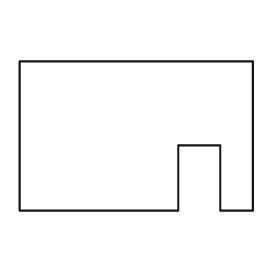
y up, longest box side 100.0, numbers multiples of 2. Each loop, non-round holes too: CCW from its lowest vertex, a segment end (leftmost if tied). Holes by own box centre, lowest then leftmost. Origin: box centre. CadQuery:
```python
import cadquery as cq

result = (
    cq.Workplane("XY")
    .moveTo(-50.0, -32.0)
    .lineTo(18.0, -32.0)
    .lineTo(18.0, -4.0)
    .lineTo(36.0, -4.0)
    .lineTo(36.0, -32.0)
    .lineTo(50.0, -32.0)
    .lineTo(50.0, 32.0)
    .lineTo(-50.0, 32.0)
    .close()
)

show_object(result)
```